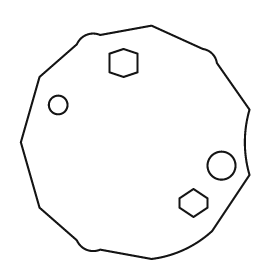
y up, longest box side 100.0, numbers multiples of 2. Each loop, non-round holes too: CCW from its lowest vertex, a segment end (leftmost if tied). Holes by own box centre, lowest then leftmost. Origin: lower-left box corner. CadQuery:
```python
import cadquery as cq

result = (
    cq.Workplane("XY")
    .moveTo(56.0, 0.0)
    .threePointArc((70.0, 4.0), (82.0, 12.0))
    .lineTo(98.0, 36.0)
    .threePointArc((96.0, 50.0), (98.0, 64.0))
    .lineTo(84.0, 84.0)
    .threePointArc((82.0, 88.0), (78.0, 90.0))
    .lineTo(56.0, 100.0)
    .lineTo(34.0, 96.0)
    .threePointArc((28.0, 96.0), (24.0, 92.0))
    .lineTo(8.0, 78.0)
    .lineTo(0.0, 50.0)
    .lineTo(8.0, 22.0)
    .lineTo(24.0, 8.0)
    .threePointArc((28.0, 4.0), (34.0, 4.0))
    .close()
    .moveTo(74.0, 18.0)
    .lineTo(80.0, 22.0)
    .lineTo(80.0, 26.0)
    .lineTo(74.0, 30.0)
    .lineTo(68.0, 26.0)
    .lineTo(68.0, 22.0)
    .close()
    .moveTo(86.0, 40.0)
    .circle(6.0)
    .moveTo(16.0, 66.0)
    .circle(4.0)
    .moveTo(44.0, 78.0)
    .lineTo(50.0, 80.0)
    .lineTo(50.0, 88.0)
    .lineTo(44.0, 90.0)
    .lineTo(38.0, 88.0)
    .lineTo(38.0, 80.0)
    .close()
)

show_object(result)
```